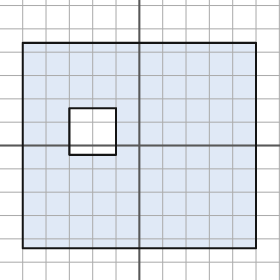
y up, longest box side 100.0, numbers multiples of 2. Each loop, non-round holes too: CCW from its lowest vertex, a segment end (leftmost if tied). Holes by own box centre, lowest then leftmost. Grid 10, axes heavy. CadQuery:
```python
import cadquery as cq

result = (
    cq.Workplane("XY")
    .moveTo(-50.0, -44.0)
    .lineTo(50.0, -44.0)
    .lineTo(50.0, 44.0)
    .lineTo(-50.0, 44.0)
    .close()
    .moveTo(-30.0, -4.0)
    .lineTo(-10.0, -4.0)
    .lineTo(-10.0, 16.0)
    .lineTo(-30.0, 16.0)
    .close()
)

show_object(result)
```